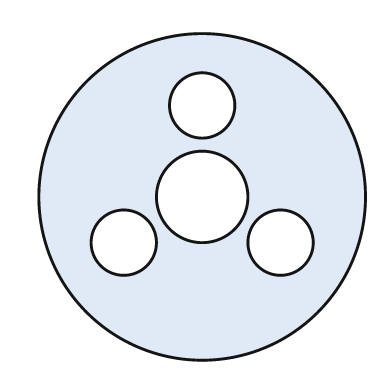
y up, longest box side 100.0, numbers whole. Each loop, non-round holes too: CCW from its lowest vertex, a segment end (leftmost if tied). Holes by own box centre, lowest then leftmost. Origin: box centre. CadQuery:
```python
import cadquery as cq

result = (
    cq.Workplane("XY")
    .moveTo(0.0, 0.0)
    .circle(50.0)
    .moveTo(-24.0, -14.0)
    .circle(10.0)
    .moveTo(24.0, -14.0)
    .circle(10.0)
    .moveTo(0.0, 0.0)
    .circle(14.0)
    .moveTo(0.0, 28.0)
    .circle(10.0)
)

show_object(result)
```